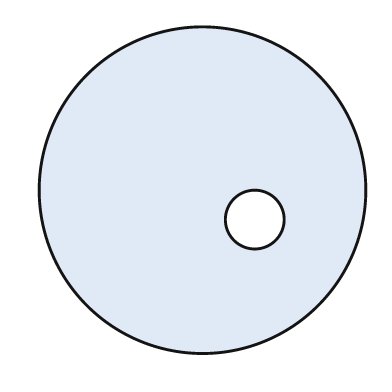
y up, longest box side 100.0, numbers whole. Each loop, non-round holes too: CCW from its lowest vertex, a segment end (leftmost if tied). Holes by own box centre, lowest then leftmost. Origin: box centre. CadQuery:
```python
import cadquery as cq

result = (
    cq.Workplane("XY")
    .moveTo(0.0, 0.0)
    .circle(50.0)
    .moveTo(16.0, -9.0)
    .circle(9.0)
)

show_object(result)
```